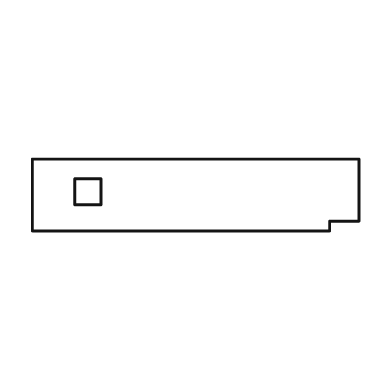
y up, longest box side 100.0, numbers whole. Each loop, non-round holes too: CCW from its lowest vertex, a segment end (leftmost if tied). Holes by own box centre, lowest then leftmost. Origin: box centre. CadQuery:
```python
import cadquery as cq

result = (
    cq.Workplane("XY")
    .moveTo(-50.0, -11.0)
    .lineTo(41.0, -11.0)
    .lineTo(41.0, -8.0)
    .lineTo(50.0, -8.0)
    .lineTo(50.0, 11.0)
    .lineTo(-50.0, 11.0)
    .close()
    .moveTo(-37.0, -3.0)
    .lineTo(-29.0, -3.0)
    .lineTo(-29.0, 5.0)
    .lineTo(-37.0, 5.0)
    .close()
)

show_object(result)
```